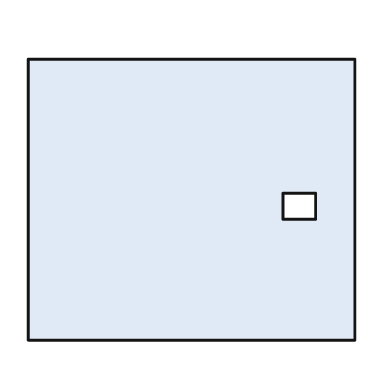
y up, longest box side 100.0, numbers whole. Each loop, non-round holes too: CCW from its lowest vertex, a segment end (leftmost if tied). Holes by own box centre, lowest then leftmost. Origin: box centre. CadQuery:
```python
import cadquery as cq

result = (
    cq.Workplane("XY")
    .moveTo(-50.0, -43.0)
    .lineTo(50.0, -43.0)
    .lineTo(50.0, 43.0)
    .lineTo(-50.0, 43.0)
    .close()
    .moveTo(28.0, -6.0)
    .lineTo(38.0, -6.0)
    .lineTo(38.0, 2.0)
    .lineTo(28.0, 2.0)
    .close()
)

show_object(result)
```